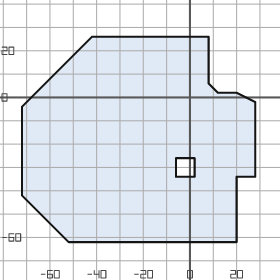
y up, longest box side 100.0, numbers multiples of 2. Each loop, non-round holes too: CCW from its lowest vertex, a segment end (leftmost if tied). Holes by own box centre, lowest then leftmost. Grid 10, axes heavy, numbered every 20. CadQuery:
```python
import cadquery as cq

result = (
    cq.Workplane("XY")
    .moveTo(-52.0, -62.0)
    .lineTo(20.0, -62.0)
    .lineTo(20.0, -34.0)
    .lineTo(28.0, -34.0)
    .lineTo(28.0, -2.0)
    .lineTo(20.0, 2.0)
    .lineTo(12.0, 2.0)
    .lineTo(8.0, 6.0)
    .lineTo(8.0, 26.0)
    .lineTo(-42.0, 26.0)
    .lineTo(-72.0, -4.0)
    .lineTo(-72.0, -42.0)
    .close()
    .moveTo(-6.0, -34.0)
    .lineTo(2.0, -34.0)
    .lineTo(2.0, -26.0)
    .lineTo(-6.0, -26.0)
    .close()
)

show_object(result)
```